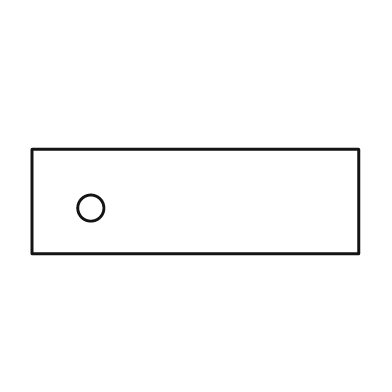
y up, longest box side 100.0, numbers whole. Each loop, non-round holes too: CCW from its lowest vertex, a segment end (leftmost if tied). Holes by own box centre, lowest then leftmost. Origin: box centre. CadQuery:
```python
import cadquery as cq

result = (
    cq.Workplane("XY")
    .moveTo(-50.0, -16.0)
    .lineTo(50.0, -16.0)
    .lineTo(50.0, 16.0)
    .lineTo(-50.0, 16.0)
    .close()
    .moveTo(-32.0, -2.0)
    .circle(4.0)
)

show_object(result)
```